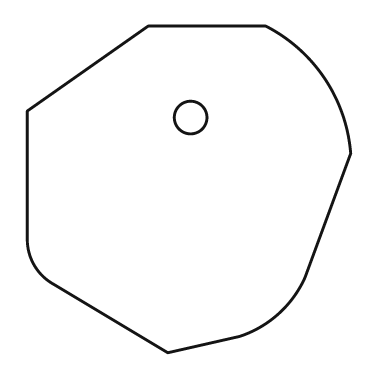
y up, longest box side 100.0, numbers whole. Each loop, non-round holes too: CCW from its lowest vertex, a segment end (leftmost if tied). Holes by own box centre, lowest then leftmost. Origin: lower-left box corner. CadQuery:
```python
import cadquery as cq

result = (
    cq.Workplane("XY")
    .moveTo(43.0, 0.0)
    .lineTo(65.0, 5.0)
    .threePointArc((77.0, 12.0), (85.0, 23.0))
    .lineTo(99.0, 61.0)
    .threePointArc((91.0, 84.0), (73.0, 100.0))
    .lineTo(37.0, 100.0)
    .lineTo(0.0, 74.0)
    .lineTo(0.0, 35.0)
    .threePointArc((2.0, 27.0), (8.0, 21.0))
    .close()
    .moveTo(50.0, 72.0)
    .circle(5.0)
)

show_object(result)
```